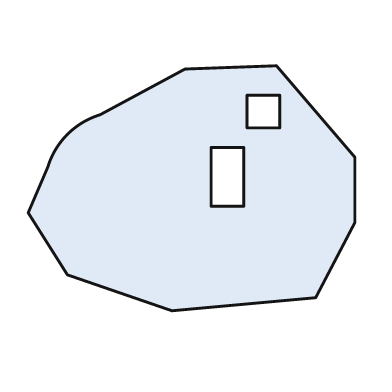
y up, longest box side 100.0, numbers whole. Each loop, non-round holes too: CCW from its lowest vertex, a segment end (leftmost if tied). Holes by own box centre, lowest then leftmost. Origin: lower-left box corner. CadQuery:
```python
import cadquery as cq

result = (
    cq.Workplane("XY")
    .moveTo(44.0, 0.0)
    .lineTo(88.0, 4.0)
    .lineTo(100.0, 27.0)
    .lineTo(100.0, 47.0)
    .lineTo(76.0, 75.0)
    .lineTo(48.0, 74.0)
    .lineTo(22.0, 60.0)
    .threePointArc((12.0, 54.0), (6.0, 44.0))
    .lineTo(0.0, 30.0)
    .lineTo(12.0, 11.0)
    .close()
    .moveTo(56.0, 32.0)
    .lineTo(66.0, 32.0)
    .lineTo(66.0, 50.0)
    .lineTo(56.0, 50.0)
    .close()
    .moveTo(67.0, 56.0)
    .lineTo(77.0, 56.0)
    .lineTo(77.0, 66.0)
    .lineTo(67.0, 66.0)
    .close()
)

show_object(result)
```